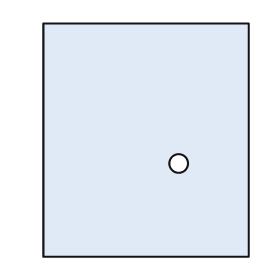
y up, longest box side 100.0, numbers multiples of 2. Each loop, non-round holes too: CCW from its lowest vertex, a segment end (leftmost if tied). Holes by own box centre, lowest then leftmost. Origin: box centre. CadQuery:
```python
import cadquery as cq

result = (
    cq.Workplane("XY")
    .moveTo(-44.0, -50.0)
    .lineTo(44.0, -50.0)
    .lineTo(44.0, 50.0)
    .lineTo(-44.0, 50.0)
    .close()
    .moveTo(14.0, -10.0)
    .circle(4.0)
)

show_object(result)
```